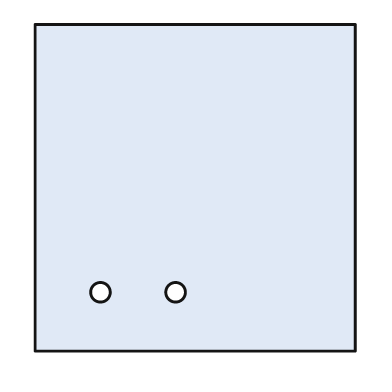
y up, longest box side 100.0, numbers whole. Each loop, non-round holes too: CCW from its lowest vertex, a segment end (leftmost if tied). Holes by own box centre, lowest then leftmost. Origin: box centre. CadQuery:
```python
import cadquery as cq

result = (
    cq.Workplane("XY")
    .moveTo(-49.0, -50.0)
    .lineTo(49.0, -50.0)
    .lineTo(49.0, 50.0)
    .lineTo(-49.0, 50.0)
    .close()
    .moveTo(-29.0, -32.0)
    .circle(3.0)
    .moveTo(-6.0, -32.0)
    .circle(3.0)
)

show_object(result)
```